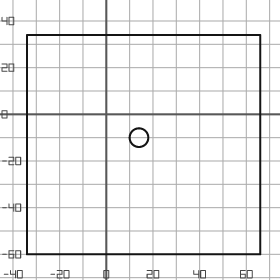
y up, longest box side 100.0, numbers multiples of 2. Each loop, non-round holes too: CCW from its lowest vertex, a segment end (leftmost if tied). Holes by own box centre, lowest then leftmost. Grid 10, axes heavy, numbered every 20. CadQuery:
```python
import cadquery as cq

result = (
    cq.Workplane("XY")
    .moveTo(-34.0, -60.0)
    .lineTo(66.0, -60.0)
    .lineTo(66.0, 34.0)
    .lineTo(-34.0, 34.0)
    .close()
    .moveTo(14.0, -10.0)
    .circle(4.0)
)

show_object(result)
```